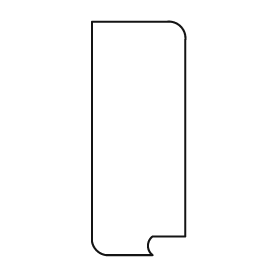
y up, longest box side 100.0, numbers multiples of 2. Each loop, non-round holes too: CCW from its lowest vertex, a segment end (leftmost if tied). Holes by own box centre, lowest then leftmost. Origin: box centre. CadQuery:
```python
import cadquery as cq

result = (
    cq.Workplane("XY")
    .moveTo(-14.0, -50.0)
    .lineTo(6.0, -50.0)
    .threePointArc((4.0, -46.0), (6.0, -42.0))
    .lineTo(20.0, -42.0)
    .lineTo(20.0, 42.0)
    .threePointArc((18.0, 48.0), (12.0, 50.0))
    .lineTo(-20.0, 50.0)
    .lineTo(-20.0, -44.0)
    .threePointArc((-18.0, -48.0), (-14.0, -50.0))
    .close()
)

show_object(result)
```